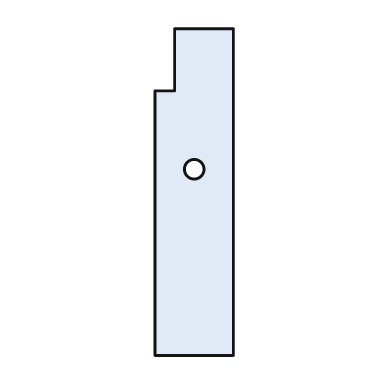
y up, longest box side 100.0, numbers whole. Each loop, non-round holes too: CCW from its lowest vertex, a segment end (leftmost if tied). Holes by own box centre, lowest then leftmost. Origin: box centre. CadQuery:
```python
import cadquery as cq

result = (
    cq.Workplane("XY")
    .moveTo(-12.0, -50.0)
    .lineTo(12.0, -50.0)
    .lineTo(12.0, 50.0)
    .lineTo(-6.0, 50.0)
    .lineTo(-6.0, 31.0)
    .lineTo(-12.0, 31.0)
    .close()
    .moveTo(0.0, 7.0)
    .circle(3.0)
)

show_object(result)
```